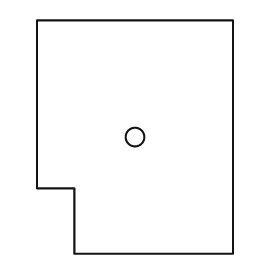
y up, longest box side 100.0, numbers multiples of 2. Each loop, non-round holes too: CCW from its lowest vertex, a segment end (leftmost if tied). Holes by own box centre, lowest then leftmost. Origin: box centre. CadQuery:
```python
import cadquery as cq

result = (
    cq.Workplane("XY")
    .moveTo(-26.0, -50.0)
    .lineTo(42.0, -50.0)
    .lineTo(42.0, 50.0)
    .lineTo(-42.0, 50.0)
    .lineTo(-42.0, -22.0)
    .lineTo(-26.0, -22.0)
    .close()
    .moveTo(0.0, 0.0)
    .circle(4.0)
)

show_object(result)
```